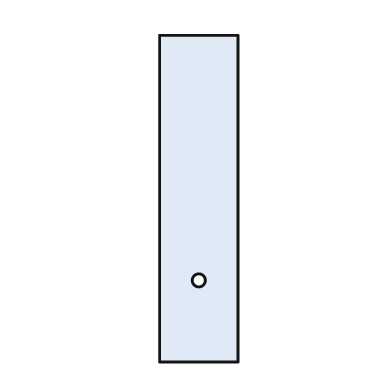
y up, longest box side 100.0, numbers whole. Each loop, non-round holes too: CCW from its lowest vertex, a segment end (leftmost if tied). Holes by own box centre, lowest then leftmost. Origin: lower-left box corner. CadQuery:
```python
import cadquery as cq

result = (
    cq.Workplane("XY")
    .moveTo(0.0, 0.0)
    .lineTo(24.0, 0.0)
    .lineTo(24.0, 100.0)
    .lineTo(0.0, 100.0)
    .close()
    .moveTo(12.0, 25.0)
    .circle(2.0)
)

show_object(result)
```